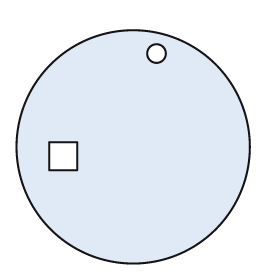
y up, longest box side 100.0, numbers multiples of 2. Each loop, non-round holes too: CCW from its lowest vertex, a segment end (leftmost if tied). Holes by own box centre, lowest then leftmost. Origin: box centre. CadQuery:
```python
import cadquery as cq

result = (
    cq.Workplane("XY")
    .moveTo(0.0, 0.0)
    .circle(50.0)
    .moveTo(-36.0, -10.0)
    .lineTo(-24.0, -10.0)
    .lineTo(-24.0, 2.0)
    .lineTo(-36.0, 2.0)
    .close()
    .moveTo(10.0, 40.0)
    .circle(4.0)
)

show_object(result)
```